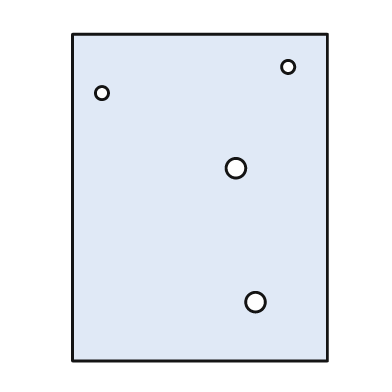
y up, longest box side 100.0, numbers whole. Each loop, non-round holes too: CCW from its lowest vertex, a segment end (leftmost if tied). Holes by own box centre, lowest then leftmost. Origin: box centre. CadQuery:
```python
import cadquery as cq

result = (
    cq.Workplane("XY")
    .moveTo(-39.0, -50.0)
    .lineTo(39.0, -50.0)
    .lineTo(39.0, 50.0)
    .lineTo(-39.0, 50.0)
    .close()
    .moveTo(17.0, -32.0)
    .circle(3.0)
    .moveTo(11.0, 9.0)
    .circle(3.0)
    .moveTo(-30.0, 32.0)
    .circle(2.0)
    .moveTo(27.0, 40.0)
    .circle(2.0)
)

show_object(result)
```